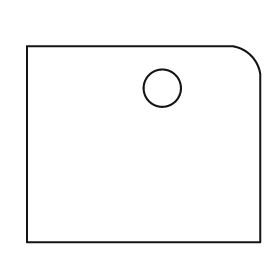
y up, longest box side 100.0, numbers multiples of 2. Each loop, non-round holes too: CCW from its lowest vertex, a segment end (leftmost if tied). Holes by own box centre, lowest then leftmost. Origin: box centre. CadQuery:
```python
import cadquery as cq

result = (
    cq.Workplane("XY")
    .moveTo(-50.0, -42.0)
    .lineTo(50.0, -42.0)
    .lineTo(50.0, 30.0)
    .threePointArc((46.0, 38.0), (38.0, 42.0))
    .lineTo(-50.0, 42.0)
    .close()
    .moveTo(8.0, 24.0)
    .circle(8.0)
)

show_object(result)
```